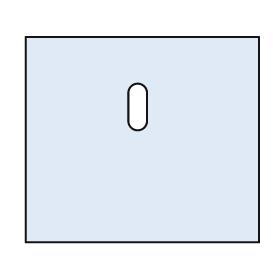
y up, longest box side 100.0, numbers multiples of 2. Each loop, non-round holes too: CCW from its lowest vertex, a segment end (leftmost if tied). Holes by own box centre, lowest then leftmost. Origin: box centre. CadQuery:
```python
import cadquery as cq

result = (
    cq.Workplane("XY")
    .moveTo(-50.0, -44.0)
    .lineTo(50.0, -44.0)
    .lineTo(50.0, 44.0)
    .lineTo(-50.0, 44.0)
    .close()
    .moveTo(-6.0, 8.0)
    .threePointArc((-2.0, 4.0), (2.0, 8.0))
    .lineTo(2.0, 20.0)
    .threePointArc((-2.0, 24.0), (-6.0, 20.0))
    .close()
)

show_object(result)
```